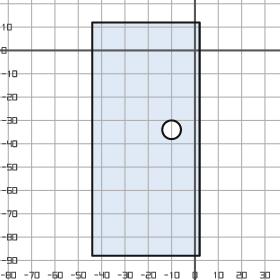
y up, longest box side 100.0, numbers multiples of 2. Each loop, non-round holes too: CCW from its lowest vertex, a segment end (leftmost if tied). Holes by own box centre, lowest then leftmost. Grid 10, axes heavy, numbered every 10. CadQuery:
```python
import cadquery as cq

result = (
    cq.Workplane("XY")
    .moveTo(-44.0, -88.0)
    .lineTo(2.0, -88.0)
    .lineTo(2.0, 12.0)
    .lineTo(-44.0, 12.0)
    .close()
    .moveTo(-10.0, -34.0)
    .circle(4.0)
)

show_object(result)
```